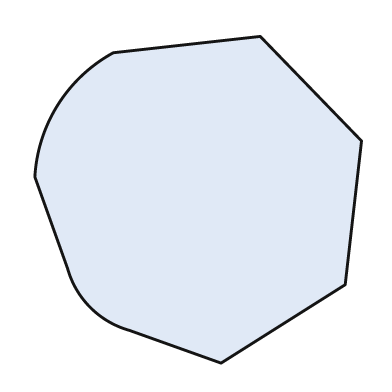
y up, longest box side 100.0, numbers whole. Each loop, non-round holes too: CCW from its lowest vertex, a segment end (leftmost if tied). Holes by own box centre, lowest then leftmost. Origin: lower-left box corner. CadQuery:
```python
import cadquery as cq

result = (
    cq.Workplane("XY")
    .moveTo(57.0, 0.0)
    .lineTo(95.0, 24.0)
    .lineTo(100.0, 68.0)
    .lineTo(69.0, 100.0)
    .lineTo(24.0, 95.0)
    .threePointArc((7.0, 79.0), (0.0, 57.0))
    .lineTo(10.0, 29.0)
    .threePointArc((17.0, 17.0), (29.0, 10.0))
    .close()
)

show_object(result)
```